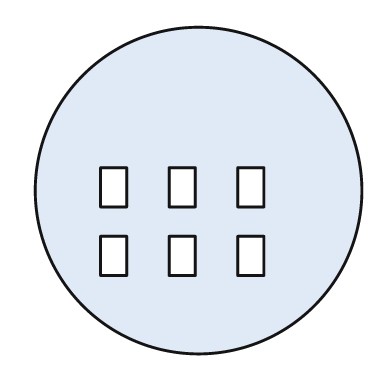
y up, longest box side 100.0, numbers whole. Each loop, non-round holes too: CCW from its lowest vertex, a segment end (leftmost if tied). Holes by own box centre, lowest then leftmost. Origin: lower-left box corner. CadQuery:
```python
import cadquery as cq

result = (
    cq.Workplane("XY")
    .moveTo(50.0, 50.0)
    .circle(50.0)
    .moveTo(20.0, 24.0)
    .lineTo(28.0, 24.0)
    .lineTo(28.0, 36.0)
    .lineTo(20.0, 36.0)
    .close()
    .moveTo(41.0, 24.0)
    .lineTo(49.0, 24.0)
    .lineTo(49.0, 36.0)
    .lineTo(41.0, 36.0)
    .close()
    .moveTo(62.0, 24.0)
    .lineTo(70.0, 24.0)
    .lineTo(70.0, 36.0)
    .lineTo(62.0, 36.0)
    .close()
    .moveTo(20.0, 45.0)
    .lineTo(28.0, 45.0)
    .lineTo(28.0, 57.0)
    .lineTo(20.0, 57.0)
    .close()
    .moveTo(41.0, 45.0)
    .lineTo(49.0, 45.0)
    .lineTo(49.0, 57.0)
    .lineTo(41.0, 57.0)
    .close()
    .moveTo(62.0, 45.0)
    .lineTo(70.0, 45.0)
    .lineTo(70.0, 57.0)
    .lineTo(62.0, 57.0)
    .close()
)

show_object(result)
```